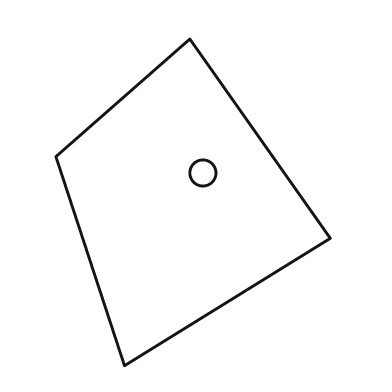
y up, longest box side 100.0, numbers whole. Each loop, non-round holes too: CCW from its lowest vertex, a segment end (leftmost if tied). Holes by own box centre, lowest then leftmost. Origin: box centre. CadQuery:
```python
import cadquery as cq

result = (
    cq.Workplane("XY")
    .moveTo(-21.0, -50.0)
    .lineTo(42.0, -11.0)
    .lineTo(-1.0, 50.0)
    .lineTo(-42.0, 14.0)
    .close()
    .moveTo(3.0, 9.0)
    .circle(4.0)
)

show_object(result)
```